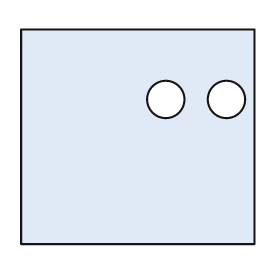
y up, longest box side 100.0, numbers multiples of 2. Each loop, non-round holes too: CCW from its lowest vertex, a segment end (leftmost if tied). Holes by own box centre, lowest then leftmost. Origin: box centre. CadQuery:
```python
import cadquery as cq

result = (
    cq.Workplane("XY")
    .moveTo(-50.0, -46.0)
    .lineTo(50.0, -46.0)
    .lineTo(50.0, 46.0)
    .lineTo(-50.0, 46.0)
    .close()
    .moveTo(12.0, 16.0)
    .circle(8.0)
    .moveTo(38.0, 16.0)
    .circle(8.0)
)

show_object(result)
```